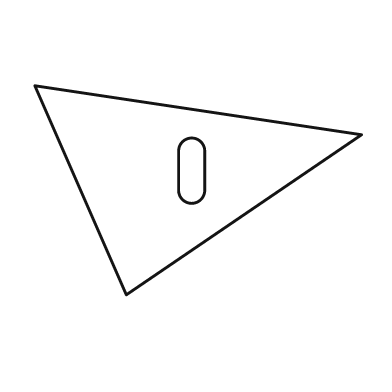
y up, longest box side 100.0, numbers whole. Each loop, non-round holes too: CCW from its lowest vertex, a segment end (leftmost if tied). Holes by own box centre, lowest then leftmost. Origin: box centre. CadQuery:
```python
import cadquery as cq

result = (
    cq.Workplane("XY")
    .moveTo(-22.0, -32.0)
    .lineTo(50.0, 17.0)
    .lineTo(-50.0, 32.0)
    .close()
    .moveTo(-6.0, 0.0)
    .threePointArc((-2.0, -4.0), (2.0, 0.0))
    .lineTo(2.0, 12.0)
    .threePointArc((-2.0, 16.0), (-6.0, 12.0))
    .close()
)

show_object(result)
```